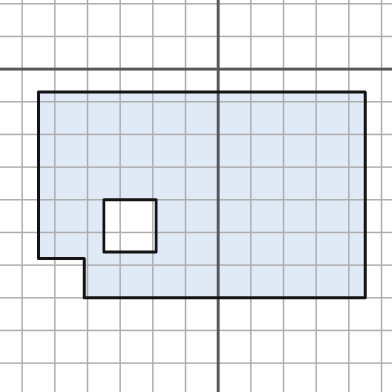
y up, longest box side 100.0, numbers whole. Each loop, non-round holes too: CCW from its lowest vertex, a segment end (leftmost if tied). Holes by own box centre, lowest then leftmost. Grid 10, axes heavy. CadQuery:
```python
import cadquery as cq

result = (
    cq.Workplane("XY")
    .moveTo(-41.0, -70.0)
    .lineTo(45.0, -70.0)
    .lineTo(45.0, -7.0)
    .lineTo(-55.0, -7.0)
    .lineTo(-55.0, -58.0)
    .lineTo(-41.0, -58.0)
    .close()
    .moveTo(-35.0, -56.0)
    .lineTo(-19.0, -56.0)
    .lineTo(-19.0, -40.0)
    .lineTo(-35.0, -40.0)
    .close()
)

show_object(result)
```